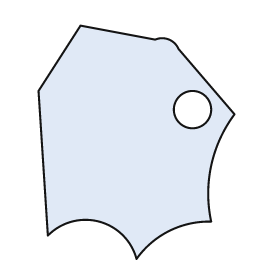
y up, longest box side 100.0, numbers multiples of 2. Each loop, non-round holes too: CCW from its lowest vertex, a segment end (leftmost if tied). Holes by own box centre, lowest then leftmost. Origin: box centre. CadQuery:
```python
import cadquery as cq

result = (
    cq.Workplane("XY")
    .moveTo(0.0, -50.0)
    .threePointArc((14.0, -38.0), (32.0, -34.0))
    .threePointArc((32.0, -10.0), (42.0, 12.0))
    .lineTo(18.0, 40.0)
    .threePointArc((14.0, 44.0), (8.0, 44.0))
    .lineTo(-24.0, 50.0)
    .lineTo(-42.0, 22.0)
    .lineTo(-38.0, -40.0)
    .threePointArc((-16.0, -34.0), (0.0, -50.0))
    .close()
    .moveTo(24.0, 14.0)
    .circle(8.0)
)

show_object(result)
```